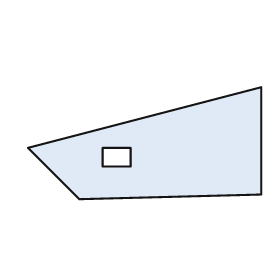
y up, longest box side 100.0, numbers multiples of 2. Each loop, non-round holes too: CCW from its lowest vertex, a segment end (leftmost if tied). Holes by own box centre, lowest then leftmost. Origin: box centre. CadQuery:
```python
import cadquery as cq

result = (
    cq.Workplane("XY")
    .moveTo(-28.0, -24.0)
    .lineTo(50.0, -22.0)
    .lineTo(50.0, 24.0)
    .lineTo(-50.0, -2.0)
    .close()
    .moveTo(-18.0, -10.0)
    .lineTo(-6.0, -10.0)
    .lineTo(-6.0, -2.0)
    .lineTo(-18.0, -2.0)
    .close()
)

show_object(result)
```